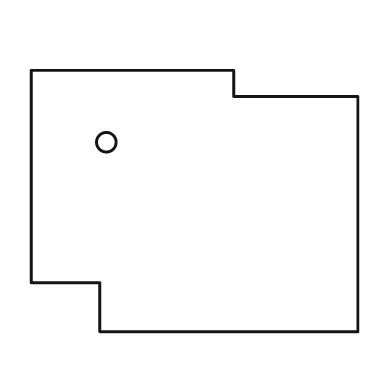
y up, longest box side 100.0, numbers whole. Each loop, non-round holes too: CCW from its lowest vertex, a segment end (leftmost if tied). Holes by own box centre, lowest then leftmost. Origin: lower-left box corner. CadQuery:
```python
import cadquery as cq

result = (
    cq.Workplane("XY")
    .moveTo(21.0, 0.0)
    .lineTo(100.0, 0.0)
    .lineTo(100.0, 72.0)
    .lineTo(62.0, 72.0)
    .lineTo(62.0, 80.0)
    .lineTo(0.0, 80.0)
    .lineTo(0.0, 15.0)
    .lineTo(21.0, 15.0)
    .close()
    .moveTo(23.0, 58.0)
    .circle(3.0)
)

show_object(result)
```